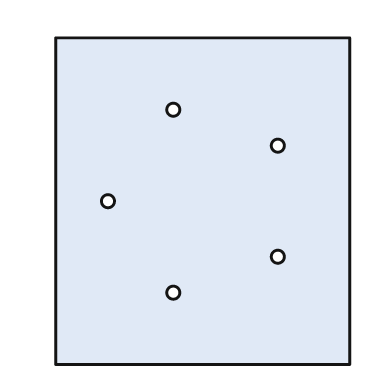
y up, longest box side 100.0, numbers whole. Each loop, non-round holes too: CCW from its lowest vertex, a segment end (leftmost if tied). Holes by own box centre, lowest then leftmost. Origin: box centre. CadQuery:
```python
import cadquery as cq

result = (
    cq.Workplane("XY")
    .moveTo(-45.0, -50.0)
    .lineTo(45.0, -50.0)
    .lineTo(45.0, 50.0)
    .lineTo(-45.0, 50.0)
    .close()
    .moveTo(-9.0, -28.0)
    .circle(2.0)
    .moveTo(23.0, -17.0)
    .circle(2.0)
    .moveTo(-29.0, 0.0)
    .circle(2.0)
    .moveTo(23.0, 17.0)
    .circle(2.0)
    .moveTo(-9.0, 28.0)
    .circle(2.0)
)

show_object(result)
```